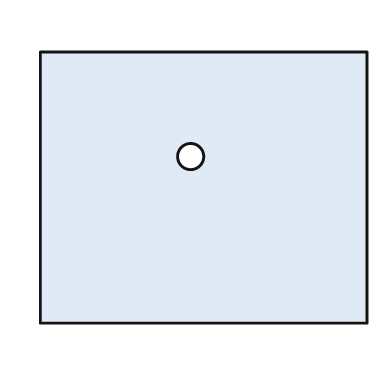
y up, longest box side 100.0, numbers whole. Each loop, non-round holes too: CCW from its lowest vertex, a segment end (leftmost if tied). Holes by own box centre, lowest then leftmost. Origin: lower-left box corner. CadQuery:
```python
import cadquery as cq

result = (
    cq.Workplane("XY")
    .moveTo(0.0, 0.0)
    .lineTo(100.0, 0.0)
    .lineTo(100.0, 83.0)
    .lineTo(0.0, 83.0)
    .close()
    .moveTo(46.0, 51.0)
    .circle(4.0)
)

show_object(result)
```